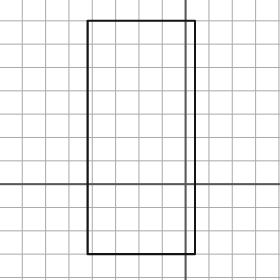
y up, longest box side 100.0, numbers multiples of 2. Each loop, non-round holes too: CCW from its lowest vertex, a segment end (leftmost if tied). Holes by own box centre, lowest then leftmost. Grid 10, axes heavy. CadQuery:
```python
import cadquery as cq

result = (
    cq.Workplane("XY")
    .moveTo(-42.0, -30.0)
    .lineTo(4.0, -30.0)
    .lineTo(4.0, 70.0)
    .lineTo(-42.0, 70.0)
    .close()
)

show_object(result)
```